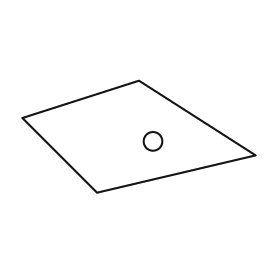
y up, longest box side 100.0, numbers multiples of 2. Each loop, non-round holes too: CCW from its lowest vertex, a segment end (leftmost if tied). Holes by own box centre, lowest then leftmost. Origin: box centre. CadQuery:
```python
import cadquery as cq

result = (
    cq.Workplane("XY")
    .moveTo(-18.0, -24.0)
    .lineTo(50.0, -8.0)
    .lineTo(0.0, 24.0)
    .lineTo(-50.0, 8.0)
    .close()
    .moveTo(6.0, -2.0)
    .circle(4.0)
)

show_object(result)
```